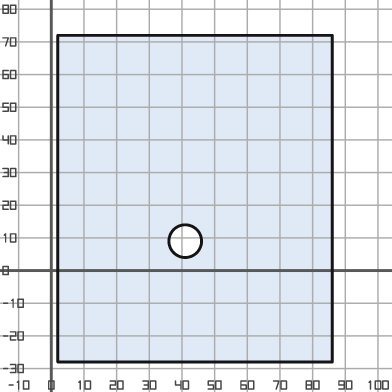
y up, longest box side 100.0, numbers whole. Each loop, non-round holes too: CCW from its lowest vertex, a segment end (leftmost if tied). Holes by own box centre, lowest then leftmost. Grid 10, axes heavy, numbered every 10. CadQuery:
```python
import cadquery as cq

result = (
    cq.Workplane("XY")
    .moveTo(2.0, -28.0)
    .lineTo(86.0, -28.0)
    .lineTo(86.0, 72.0)
    .lineTo(2.0, 72.0)
    .close()
    .moveTo(41.0, 9.0)
    .circle(5.0)
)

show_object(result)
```